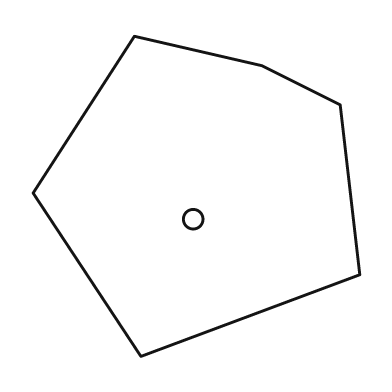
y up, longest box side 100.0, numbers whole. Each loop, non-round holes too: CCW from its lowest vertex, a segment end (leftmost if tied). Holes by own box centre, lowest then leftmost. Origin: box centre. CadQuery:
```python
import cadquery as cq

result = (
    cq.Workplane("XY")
    .moveTo(-17.0, -49.0)
    .lineTo(50.0, -24.0)
    .lineTo(44.0, 28.0)
    .lineTo(20.0, 40.0)
    .lineTo(-19.0, 49.0)
    .lineTo(-50.0, 1.0)
    .close()
    .moveTo(-1.0, -7.0)
    .circle(3.0)
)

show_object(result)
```